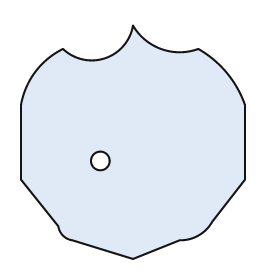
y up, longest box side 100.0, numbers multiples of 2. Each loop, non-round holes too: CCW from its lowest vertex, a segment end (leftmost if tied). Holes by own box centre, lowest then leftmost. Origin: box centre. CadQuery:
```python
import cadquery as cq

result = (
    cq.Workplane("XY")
    .moveTo(0.0, -50.0)
    .lineTo(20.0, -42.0)
    .threePointArc((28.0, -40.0), (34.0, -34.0))
    .lineTo(48.0, -16.0)
    .lineTo(48.0, 16.0)
    .threePointArc((40.0, 30.0), (28.0, 40.0))
    .threePointArc((12.0, 40.0), (0.0, 50.0))
    .threePointArc((-12.0, 36.0), (-30.0, 40.0))
    .threePointArc((-42.0, 30.0), (-48.0, 16.0))
    .lineTo(-48.0, -16.0)
    .lineTo(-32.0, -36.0)
    .threePointArc((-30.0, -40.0), (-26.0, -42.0))
    .close()
    .moveTo(-14.0, -8.0)
    .circle(4.0)
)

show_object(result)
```